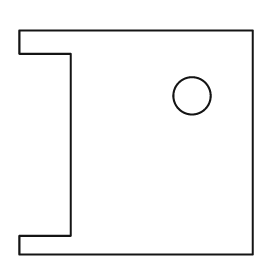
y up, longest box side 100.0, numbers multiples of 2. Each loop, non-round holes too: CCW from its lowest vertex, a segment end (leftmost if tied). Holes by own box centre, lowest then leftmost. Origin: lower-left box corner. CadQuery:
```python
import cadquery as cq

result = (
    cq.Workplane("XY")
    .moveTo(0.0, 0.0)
    .lineTo(100.0, 0.0)
    .lineTo(100.0, 96.0)
    .lineTo(0.0, 96.0)
    .lineTo(0.0, 86.0)
    .lineTo(22.0, 86.0)
    .lineTo(22.0, 8.0)
    .lineTo(0.0, 8.0)
    .close()
    .moveTo(74.0, 68.0)
    .circle(8.0)
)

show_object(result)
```